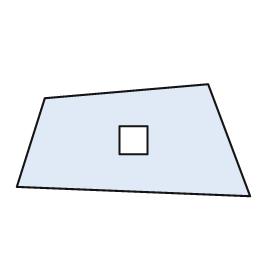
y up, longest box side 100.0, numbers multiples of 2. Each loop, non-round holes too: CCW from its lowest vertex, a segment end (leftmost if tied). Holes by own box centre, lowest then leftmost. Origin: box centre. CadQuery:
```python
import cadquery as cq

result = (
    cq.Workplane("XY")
    .moveTo(50.0, -24.0)
    .lineTo(32.0, 24.0)
    .lineTo(-38.0, 18.0)
    .lineTo(-50.0, -20.0)
    .close()
    .moveTo(-6.0, -6.0)
    .lineTo(6.0, -6.0)
    .lineTo(6.0, 6.0)
    .lineTo(-6.0, 6.0)
    .close()
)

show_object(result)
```